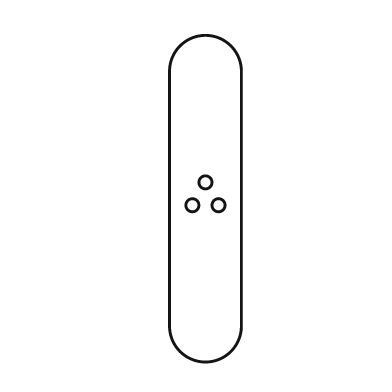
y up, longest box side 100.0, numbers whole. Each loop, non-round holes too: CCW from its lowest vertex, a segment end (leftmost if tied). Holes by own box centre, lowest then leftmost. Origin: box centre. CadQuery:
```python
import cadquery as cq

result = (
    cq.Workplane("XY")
    .moveTo(-11.0, -39.0)
    .threePointArc((0.0, -50.0), (11.0, -39.0))
    .lineTo(11.0, 39.0)
    .threePointArc((0.0, 50.0), (-11.0, 39.0))
    .close()
    .moveTo(-4.0, -2.0)
    .circle(2.0)
    .moveTo(4.0, -2.0)
    .circle(2.0)
    .moveTo(0.0, 5.0)
    .circle(2.0)
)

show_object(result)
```